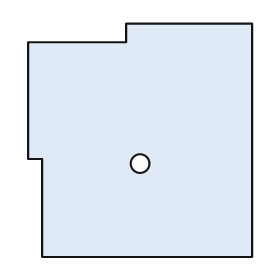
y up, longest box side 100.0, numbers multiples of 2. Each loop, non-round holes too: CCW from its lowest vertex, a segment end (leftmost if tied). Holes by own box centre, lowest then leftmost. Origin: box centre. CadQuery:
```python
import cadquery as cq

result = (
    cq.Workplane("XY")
    .moveTo(-42.0, -50.0)
    .lineTo(48.0, -50.0)
    .lineTo(48.0, 50.0)
    .lineTo(-6.0, 50.0)
    .lineTo(-6.0, 42.0)
    .lineTo(-48.0, 42.0)
    .lineTo(-48.0, -8.0)
    .lineTo(-42.0, -8.0)
    .close()
    .moveTo(0.0, -10.0)
    .circle(4.0)
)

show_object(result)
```